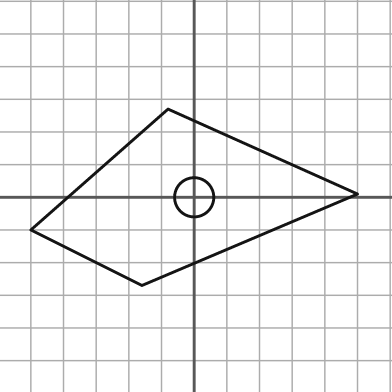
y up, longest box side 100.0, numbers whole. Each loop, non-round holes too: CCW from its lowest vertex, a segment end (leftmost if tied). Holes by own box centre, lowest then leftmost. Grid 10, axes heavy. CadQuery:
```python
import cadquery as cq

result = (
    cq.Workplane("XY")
    .moveTo(-16.0, -27.0)
    .lineTo(50.0, 1.0)
    .lineTo(-8.0, 27.0)
    .lineTo(-50.0, -10.0)
    .close()
    .moveTo(0.0, 0.0)
    .circle(6.0)
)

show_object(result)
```